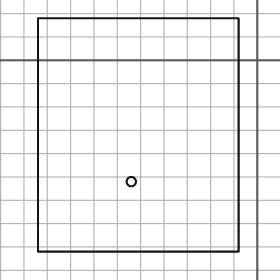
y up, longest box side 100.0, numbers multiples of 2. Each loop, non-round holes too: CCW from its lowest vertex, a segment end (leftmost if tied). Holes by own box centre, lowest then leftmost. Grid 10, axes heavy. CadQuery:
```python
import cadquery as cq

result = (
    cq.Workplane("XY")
    .moveTo(-94.0, -82.0)
    .lineTo(-8.0, -82.0)
    .lineTo(-8.0, 18.0)
    .lineTo(-94.0, 18.0)
    .close()
    .moveTo(-54.0, -52.0)
    .circle(2.0)
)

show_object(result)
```